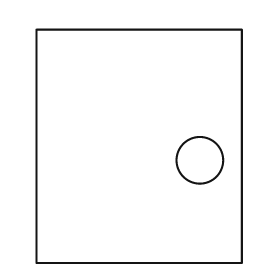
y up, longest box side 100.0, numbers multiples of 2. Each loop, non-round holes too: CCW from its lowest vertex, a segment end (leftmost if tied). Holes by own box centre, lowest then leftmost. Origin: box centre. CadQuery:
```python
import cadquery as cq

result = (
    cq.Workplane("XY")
    .moveTo(-44.0, -50.0)
    .lineTo(44.0, -50.0)
    .lineTo(44.0, 50.0)
    .lineTo(-44.0, 50.0)
    .close()
    .moveTo(26.0, -6.0)
    .circle(10.0)
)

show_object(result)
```